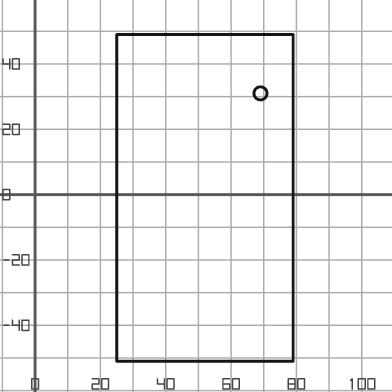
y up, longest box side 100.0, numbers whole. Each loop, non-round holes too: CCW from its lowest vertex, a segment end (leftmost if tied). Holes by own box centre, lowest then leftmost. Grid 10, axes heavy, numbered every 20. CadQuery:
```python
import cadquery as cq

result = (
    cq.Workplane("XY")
    .moveTo(25.0, -51.0)
    .lineTo(79.0, -51.0)
    .lineTo(79.0, 49.0)
    .lineTo(25.0, 49.0)
    .close()
    .moveTo(69.0, 31.0)
    .circle(2.0)
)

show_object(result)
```